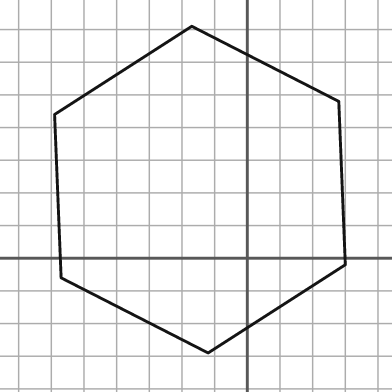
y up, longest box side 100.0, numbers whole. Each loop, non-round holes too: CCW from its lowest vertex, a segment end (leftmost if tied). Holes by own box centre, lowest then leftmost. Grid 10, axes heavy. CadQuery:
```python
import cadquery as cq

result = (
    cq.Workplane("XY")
    .moveTo(-12.0, -29.0)
    .lineTo(30.0, -2.0)
    .lineTo(28.0, 48.0)
    .lineTo(-17.0, 71.0)
    .lineTo(-59.0, 44.0)
    .lineTo(-57.0, -6.0)
    .close()
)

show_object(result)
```